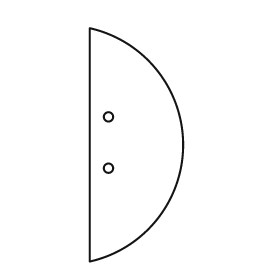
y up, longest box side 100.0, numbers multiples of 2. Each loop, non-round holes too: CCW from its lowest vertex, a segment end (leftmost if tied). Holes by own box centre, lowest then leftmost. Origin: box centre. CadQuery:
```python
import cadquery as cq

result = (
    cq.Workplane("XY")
    .moveTo(-20.0, -50.0)
    .threePointArc((20.0, 0.0), (-20.0, 50.0))
    .close()
    .moveTo(-12.0, -10.0)
    .circle(2.0)
    .moveTo(-12.0, 12.0)
    .circle(2.0)
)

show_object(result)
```